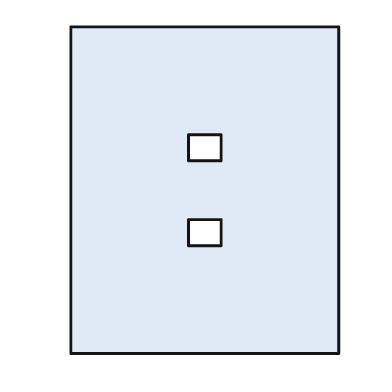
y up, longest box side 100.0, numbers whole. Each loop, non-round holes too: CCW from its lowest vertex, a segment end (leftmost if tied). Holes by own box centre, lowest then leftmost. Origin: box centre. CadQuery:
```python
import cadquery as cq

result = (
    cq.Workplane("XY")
    .moveTo(-41.0, -50.0)
    .lineTo(41.0, -50.0)
    .lineTo(41.0, 50.0)
    .lineTo(-41.0, 50.0)
    .close()
    .moveTo(-5.0, -17.0)
    .lineTo(5.0, -17.0)
    .lineTo(5.0, -9.0)
    .lineTo(-5.0, -9.0)
    .close()
    .moveTo(-5.0, 9.0)
    .lineTo(5.0, 9.0)
    .lineTo(5.0, 17.0)
    .lineTo(-5.0, 17.0)
    .close()
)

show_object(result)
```